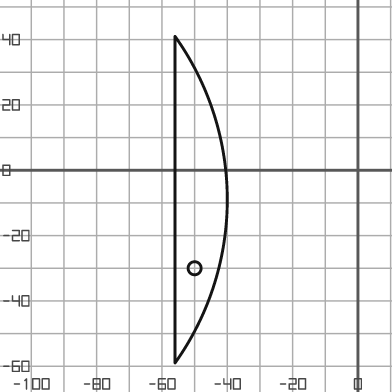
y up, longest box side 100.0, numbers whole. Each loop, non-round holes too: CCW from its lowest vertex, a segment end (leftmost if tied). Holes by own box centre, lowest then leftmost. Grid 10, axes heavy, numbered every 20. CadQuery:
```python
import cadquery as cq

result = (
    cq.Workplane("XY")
    .moveTo(-56.0, -59.0)
    .threePointArc((-40.0, -9.0), (-56.0, 41.0))
    .close()
    .moveTo(-50.0, -30.0)
    .circle(2.0)
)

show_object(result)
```